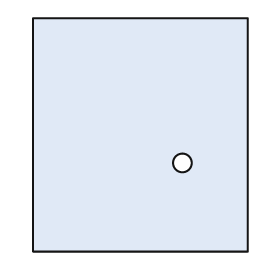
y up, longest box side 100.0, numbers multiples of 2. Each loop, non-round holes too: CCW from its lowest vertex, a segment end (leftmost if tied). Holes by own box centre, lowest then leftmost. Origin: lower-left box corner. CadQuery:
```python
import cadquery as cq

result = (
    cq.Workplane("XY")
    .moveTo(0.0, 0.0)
    .lineTo(92.0, 0.0)
    .lineTo(92.0, 100.0)
    .lineTo(0.0, 100.0)
    .close()
    .moveTo(64.0, 38.0)
    .circle(4.0)
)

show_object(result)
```